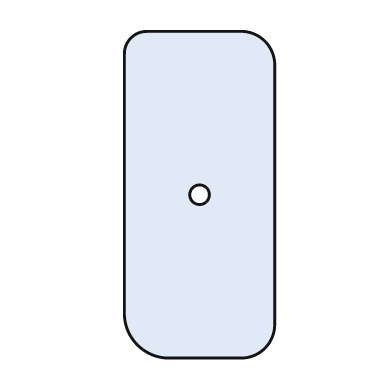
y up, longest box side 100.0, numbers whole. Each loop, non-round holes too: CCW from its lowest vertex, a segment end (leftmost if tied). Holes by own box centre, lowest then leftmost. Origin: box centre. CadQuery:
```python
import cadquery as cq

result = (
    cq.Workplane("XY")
    .moveTo(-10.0, -50.0)
    .lineTo(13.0, -50.0)
    .threePointArc((20.0, -47.0), (23.0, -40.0))
    .lineTo(23.0, 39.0)
    .threePointArc((20.0, 47.0), (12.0, 50.0))
    .lineTo(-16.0, 50.0)
    .threePointArc((-21.0, 48.0), (-23.0, 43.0))
    .lineTo(-23.0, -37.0)
    .threePointArc((-19.0, -46.0), (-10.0, -50.0))
    .close()
    .moveTo(0.0, 0.0)
    .circle(3.0)
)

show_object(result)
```